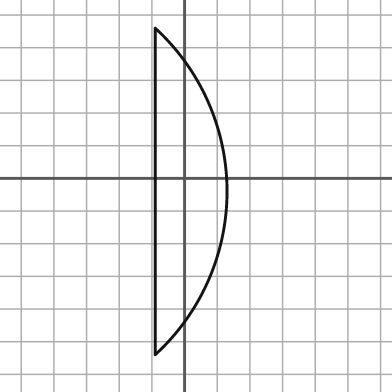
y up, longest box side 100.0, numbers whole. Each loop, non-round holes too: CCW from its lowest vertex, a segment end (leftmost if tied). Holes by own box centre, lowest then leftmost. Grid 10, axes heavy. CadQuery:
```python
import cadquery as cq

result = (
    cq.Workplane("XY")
    .moveTo(-9.0, -54.0)
    .threePointArc((13.0, -4.0), (-9.0, 46.0))
    .close()
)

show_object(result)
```